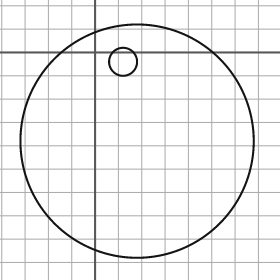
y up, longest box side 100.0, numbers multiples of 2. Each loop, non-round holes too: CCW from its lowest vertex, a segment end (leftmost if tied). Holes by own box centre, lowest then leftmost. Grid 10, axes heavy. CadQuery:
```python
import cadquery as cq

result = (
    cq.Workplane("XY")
    .moveTo(18.0, -38.0)
    .circle(50.0)
    .moveTo(12.0, -4.0)
    .circle(6.0)
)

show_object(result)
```